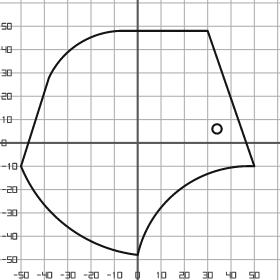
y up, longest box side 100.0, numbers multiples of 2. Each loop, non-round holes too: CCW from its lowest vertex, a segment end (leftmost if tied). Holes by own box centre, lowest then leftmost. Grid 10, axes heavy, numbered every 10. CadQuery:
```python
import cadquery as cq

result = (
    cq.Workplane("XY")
    .moveTo(0.0, -48.0)
    .threePointArc((18.0, -20.0), (50.0, -10.0))
    .lineTo(30.0, 48.0)
    .lineTo(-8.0, 48.0)
    .threePointArc((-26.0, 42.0), (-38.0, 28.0))
    .lineTo(-50.0, -10.0)
    .threePointArc((-30.0, -36.0), (0.0, -48.0))
    .close()
    .moveTo(34.0, 6.0)
    .circle(2.0)
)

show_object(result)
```